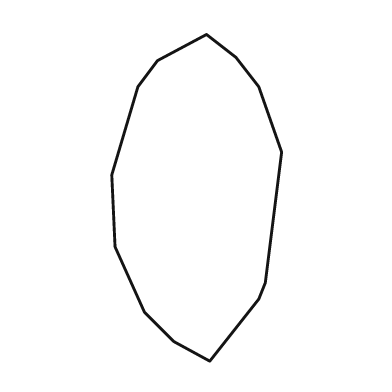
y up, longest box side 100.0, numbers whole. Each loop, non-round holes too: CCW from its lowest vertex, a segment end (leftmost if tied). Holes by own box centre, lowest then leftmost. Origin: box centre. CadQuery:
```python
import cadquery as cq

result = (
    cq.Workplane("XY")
    .moveTo(4.0, -50.0)
    .lineTo(19.0, -31.0)
    .lineTo(21.0, -26.0)
    .lineTo(26.0, 14.0)
    .lineTo(19.0, 34.0)
    .lineTo(12.0, 43.0)
    .lineTo(3.0, 50.0)
    .lineTo(-12.0, 42.0)
    .lineTo(-18.0, 34.0)
    .lineTo(-26.0, 7.0)
    .lineTo(-25.0, -15.0)
    .lineTo(-16.0, -35.0)
    .lineTo(-7.0, -44.0)
    .close()
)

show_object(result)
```